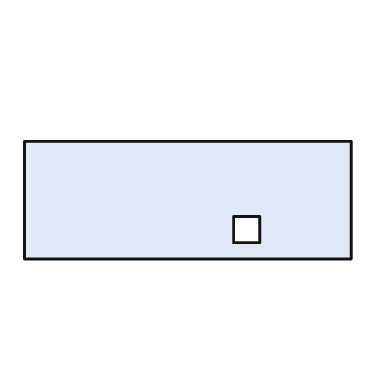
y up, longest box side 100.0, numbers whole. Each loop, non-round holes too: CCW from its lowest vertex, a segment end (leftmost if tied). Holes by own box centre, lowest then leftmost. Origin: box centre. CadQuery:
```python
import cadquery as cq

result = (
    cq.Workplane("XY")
    .moveTo(-50.0, -18.0)
    .lineTo(50.0, -18.0)
    .lineTo(50.0, 18.0)
    .lineTo(-50.0, 18.0)
    .close()
    .moveTo(14.0, -13.0)
    .lineTo(22.0, -13.0)
    .lineTo(22.0, -5.0)
    .lineTo(14.0, -5.0)
    .close()
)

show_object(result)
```